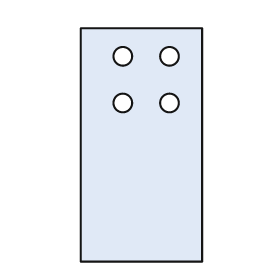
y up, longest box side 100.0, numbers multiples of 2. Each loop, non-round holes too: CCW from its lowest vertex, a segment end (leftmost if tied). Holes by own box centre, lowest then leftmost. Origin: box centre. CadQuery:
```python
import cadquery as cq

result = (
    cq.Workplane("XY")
    .moveTo(-26.0, -50.0)
    .lineTo(26.0, -50.0)
    .lineTo(26.0, 50.0)
    .lineTo(-26.0, 50.0)
    .close()
    .moveTo(-8.0, 18.0)
    .circle(4.0)
    .moveTo(12.0, 18.0)
    .circle(4.0)
    .moveTo(-8.0, 38.0)
    .circle(4.0)
    .moveTo(12.0, 38.0)
    .circle(4.0)
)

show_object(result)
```